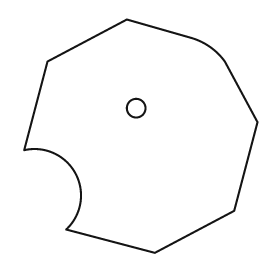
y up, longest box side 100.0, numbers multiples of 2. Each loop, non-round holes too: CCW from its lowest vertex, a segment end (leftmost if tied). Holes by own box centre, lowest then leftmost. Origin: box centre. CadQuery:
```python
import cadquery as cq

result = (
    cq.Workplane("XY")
    .moveTo(6.0, -50.0)
    .lineTo(40.0, -32.0)
    .lineTo(50.0, 6.0)
    .lineTo(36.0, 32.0)
    .threePointArc((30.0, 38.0), (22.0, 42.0))
    .lineTo(-6.0, 50.0)
    .lineTo(-40.0, 32.0)
    .lineTo(-50.0, -6.0)
    .threePointArc((-28.0, -16.0), (-32.0, -40.0))
    .close()
    .moveTo(-2.0, 12.0)
    .circle(4.0)
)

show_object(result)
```